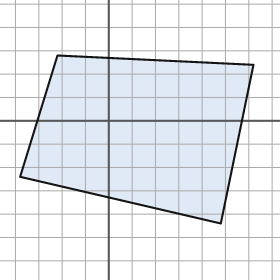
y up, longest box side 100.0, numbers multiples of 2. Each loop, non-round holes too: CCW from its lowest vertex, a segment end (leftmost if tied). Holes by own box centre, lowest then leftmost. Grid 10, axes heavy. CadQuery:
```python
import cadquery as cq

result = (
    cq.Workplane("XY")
    .moveTo(48.0, -44.0)
    .lineTo(62.0, 24.0)
    .lineTo(-22.0, 28.0)
    .lineTo(-38.0, -24.0)
    .close()
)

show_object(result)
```